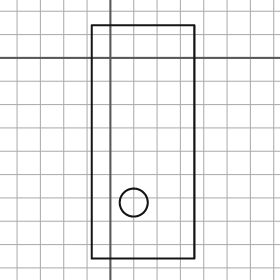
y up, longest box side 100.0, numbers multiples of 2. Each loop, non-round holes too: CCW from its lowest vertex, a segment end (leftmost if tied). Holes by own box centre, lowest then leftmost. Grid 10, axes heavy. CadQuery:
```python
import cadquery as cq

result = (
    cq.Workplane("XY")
    .moveTo(-8.0, -86.0)
    .lineTo(36.0, -86.0)
    .lineTo(36.0, 14.0)
    .lineTo(-8.0, 14.0)
    .close()
    .moveTo(10.0, -62.0)
    .circle(6.0)
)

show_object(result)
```